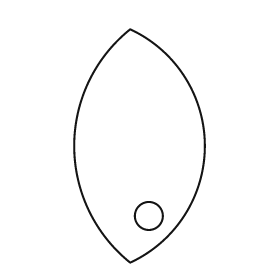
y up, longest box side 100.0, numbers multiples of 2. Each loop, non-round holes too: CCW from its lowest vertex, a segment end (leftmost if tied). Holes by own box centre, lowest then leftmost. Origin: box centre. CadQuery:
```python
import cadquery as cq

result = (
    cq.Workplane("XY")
    .moveTo(-4.0, -50.0)
    .threePointArc((28.0, 0.0), (-4.0, 50.0))
    .threePointArc((-28.0, 0.0), (-4.0, -50.0))
    .close()
    .moveTo(4.0, -30.0)
    .circle(6.0)
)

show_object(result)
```